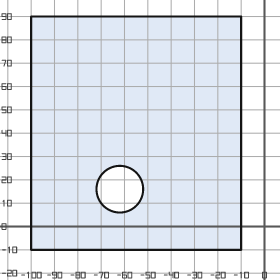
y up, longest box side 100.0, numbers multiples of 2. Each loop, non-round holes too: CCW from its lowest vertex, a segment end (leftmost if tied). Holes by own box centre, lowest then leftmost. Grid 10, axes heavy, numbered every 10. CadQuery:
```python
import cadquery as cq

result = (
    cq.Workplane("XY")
    .moveTo(-100.0, -10.0)
    .lineTo(-10.0, -10.0)
    .lineTo(-10.0, 90.0)
    .lineTo(-100.0, 90.0)
    .close()
    .moveTo(-62.0, 16.0)
    .circle(10.0)
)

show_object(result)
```